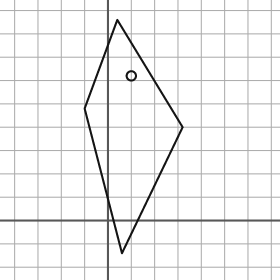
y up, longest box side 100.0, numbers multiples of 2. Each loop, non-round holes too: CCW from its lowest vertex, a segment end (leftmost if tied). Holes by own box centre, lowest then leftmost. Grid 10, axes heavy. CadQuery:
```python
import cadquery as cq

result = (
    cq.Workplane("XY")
    .moveTo(6.0, -14.0)
    .lineTo(32.0, 40.0)
    .lineTo(4.0, 86.0)
    .lineTo(-10.0, 48.0)
    .close()
    .moveTo(10.0, 62.0)
    .circle(2.0)
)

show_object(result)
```